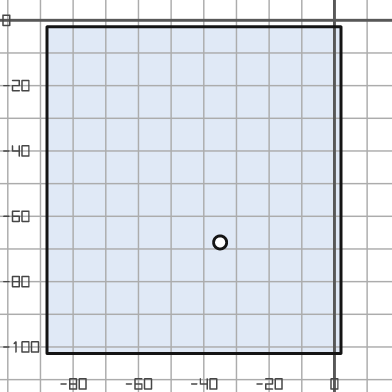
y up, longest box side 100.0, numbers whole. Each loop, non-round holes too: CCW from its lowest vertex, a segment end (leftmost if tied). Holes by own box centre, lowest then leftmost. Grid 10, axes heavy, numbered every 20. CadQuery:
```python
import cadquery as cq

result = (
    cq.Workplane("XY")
    .moveTo(-88.0, -102.0)
    .lineTo(2.0, -102.0)
    .lineTo(2.0, -2.0)
    .lineTo(-88.0, -2.0)
    .close()
    .moveTo(-35.0, -68.0)
    .circle(2.0)
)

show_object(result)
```